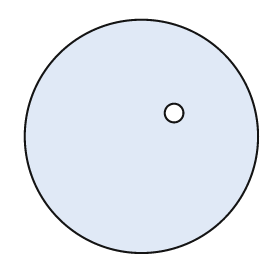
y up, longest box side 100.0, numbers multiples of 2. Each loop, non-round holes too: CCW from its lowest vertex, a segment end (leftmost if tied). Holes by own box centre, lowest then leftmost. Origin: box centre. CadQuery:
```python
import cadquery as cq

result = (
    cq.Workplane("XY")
    .moveTo(0.0, 0.0)
    .circle(50.0)
    .moveTo(14.0, 10.0)
    .circle(4.0)
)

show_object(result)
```